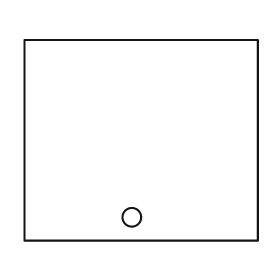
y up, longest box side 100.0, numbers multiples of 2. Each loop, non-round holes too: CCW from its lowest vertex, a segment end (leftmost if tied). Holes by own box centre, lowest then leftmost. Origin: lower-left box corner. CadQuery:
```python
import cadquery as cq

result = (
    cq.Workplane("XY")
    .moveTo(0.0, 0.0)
    .lineTo(100.0, 0.0)
    .lineTo(100.0, 86.0)
    .lineTo(0.0, 86.0)
    .close()
    .moveTo(46.0, 10.0)
    .circle(4.0)
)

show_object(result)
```